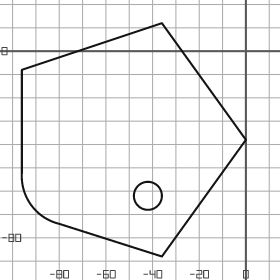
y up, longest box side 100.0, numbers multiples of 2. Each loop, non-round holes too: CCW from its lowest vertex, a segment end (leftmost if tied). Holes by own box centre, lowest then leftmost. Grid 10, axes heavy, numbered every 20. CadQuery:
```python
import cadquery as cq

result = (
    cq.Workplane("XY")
    .moveTo(-36.0, -88.0)
    .lineTo(0.0, -38.0)
    .lineTo(-36.0, 12.0)
    .lineTo(-96.0, -8.0)
    .lineTo(-96.0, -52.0)
    .threePointArc((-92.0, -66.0), (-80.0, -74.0))
    .close()
    .moveTo(-42.0, -62.0)
    .circle(6.0)
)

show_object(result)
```